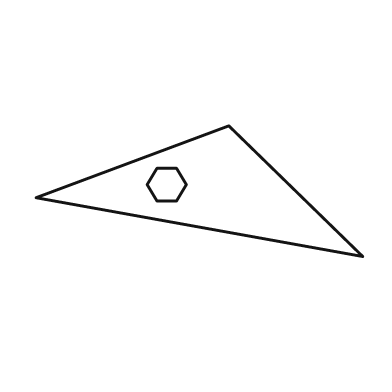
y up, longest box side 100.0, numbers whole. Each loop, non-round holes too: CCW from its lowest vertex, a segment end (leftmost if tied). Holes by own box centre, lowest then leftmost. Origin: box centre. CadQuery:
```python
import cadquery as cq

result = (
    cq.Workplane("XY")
    .moveTo(50.0, -20.0)
    .lineTo(9.0, 20.0)
    .lineTo(-50.0, -2.0)
    .close()
    .moveTo(-13.0, -3.0)
    .lineTo(-7.0, -3.0)
    .lineTo(-4.0, 2.0)
    .lineTo(-7.0, 7.0)
    .lineTo(-13.0, 7.0)
    .lineTo(-16.0, 2.0)
    .close()
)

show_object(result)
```